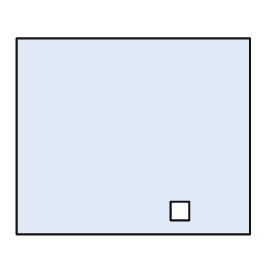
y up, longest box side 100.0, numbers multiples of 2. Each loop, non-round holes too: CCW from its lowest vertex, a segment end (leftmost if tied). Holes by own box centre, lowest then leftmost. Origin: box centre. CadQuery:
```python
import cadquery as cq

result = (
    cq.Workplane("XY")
    .moveTo(-50.0, -42.0)
    .lineTo(50.0, -42.0)
    .lineTo(50.0, 42.0)
    .lineTo(-50.0, 42.0)
    .close()
    .moveTo(16.0, -36.0)
    .lineTo(24.0, -36.0)
    .lineTo(24.0, -28.0)
    .lineTo(16.0, -28.0)
    .close()
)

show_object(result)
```